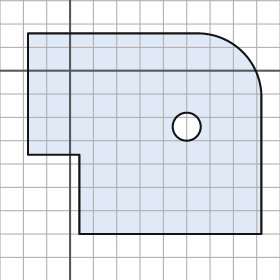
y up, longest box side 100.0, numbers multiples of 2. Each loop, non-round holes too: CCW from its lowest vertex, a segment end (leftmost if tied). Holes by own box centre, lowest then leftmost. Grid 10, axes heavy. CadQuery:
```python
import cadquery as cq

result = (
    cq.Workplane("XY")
    .moveTo(4.0, -70.0)
    .lineTo(82.0, -70.0)
    .lineTo(82.0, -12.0)
    .threePointArc((74.0, 8.0), (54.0, 16.0))
    .lineTo(-18.0, 16.0)
    .lineTo(-18.0, -36.0)
    .lineTo(4.0, -36.0)
    .close()
    .moveTo(50.0, -24.0)
    .circle(6.0)
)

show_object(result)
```